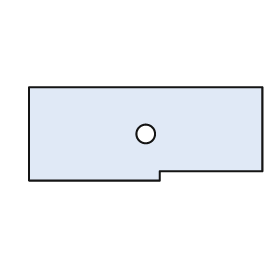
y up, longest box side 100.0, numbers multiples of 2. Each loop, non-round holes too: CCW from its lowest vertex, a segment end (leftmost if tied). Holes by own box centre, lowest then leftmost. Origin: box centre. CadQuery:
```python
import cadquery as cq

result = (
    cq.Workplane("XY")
    .moveTo(-50.0, -20.0)
    .lineTo(6.0, -20.0)
    .lineTo(6.0, -16.0)
    .lineTo(50.0, -16.0)
    .lineTo(50.0, 20.0)
    .lineTo(-50.0, 20.0)
    .close()
    .moveTo(0.0, 0.0)
    .circle(4.0)
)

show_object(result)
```